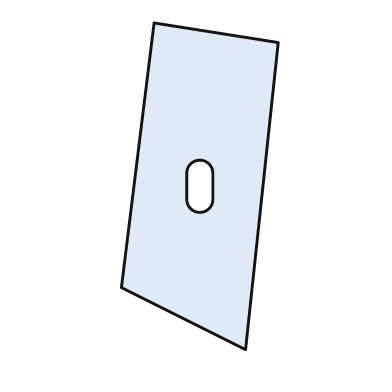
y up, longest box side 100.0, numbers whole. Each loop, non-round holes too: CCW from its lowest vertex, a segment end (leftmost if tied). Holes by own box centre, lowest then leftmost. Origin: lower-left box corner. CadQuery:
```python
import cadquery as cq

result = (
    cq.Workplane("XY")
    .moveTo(38.0, 0.0)
    .lineTo(48.0, 94.0)
    .lineTo(10.0, 100.0)
    .lineTo(0.0, 19.0)
    .close()
    .moveTo(20.0, 46.0)
    .threePointArc((24.0, 42.0), (28.0, 46.0))
    .lineTo(28.0, 54.0)
    .threePointArc((24.0, 58.0), (20.0, 54.0))
    .close()
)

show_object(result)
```